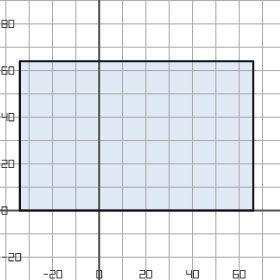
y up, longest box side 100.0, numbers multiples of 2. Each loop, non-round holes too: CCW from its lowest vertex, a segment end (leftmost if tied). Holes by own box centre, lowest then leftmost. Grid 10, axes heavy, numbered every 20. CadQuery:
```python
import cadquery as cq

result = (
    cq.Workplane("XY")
    .moveTo(-34.0, 0.0)
    .lineTo(66.0, 0.0)
    .lineTo(66.0, 64.0)
    .lineTo(-34.0, 64.0)
    .close()
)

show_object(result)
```